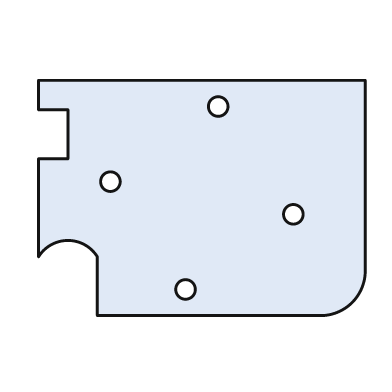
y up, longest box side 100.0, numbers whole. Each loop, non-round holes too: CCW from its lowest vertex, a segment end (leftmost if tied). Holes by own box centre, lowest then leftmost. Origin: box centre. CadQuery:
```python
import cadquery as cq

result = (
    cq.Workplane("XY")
    .moveTo(-32.0, -36.0)
    .lineTo(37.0, -36.0)
    .threePointArc((46.0, -32.0), (50.0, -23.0))
    .lineTo(50.0, 36.0)
    .lineTo(-50.0, 36.0)
    .lineTo(-50.0, 27.0)
    .lineTo(-41.0, 27.0)
    .lineTo(-41.0, 12.0)
    .lineTo(-50.0, 12.0)
    .lineTo(-50.0, -18.0)
    .threePointArc((-41.0, -13.0), (-32.0, -18.0))
    .close()
    .moveTo(-5.0, -28.0)
    .circle(3.0)
    .moveTo(28.0, -5.0)
    .circle(3.0)
    .moveTo(-28.0, 5.0)
    .circle(3.0)
    .moveTo(5.0, 28.0)
    .circle(3.0)
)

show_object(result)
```